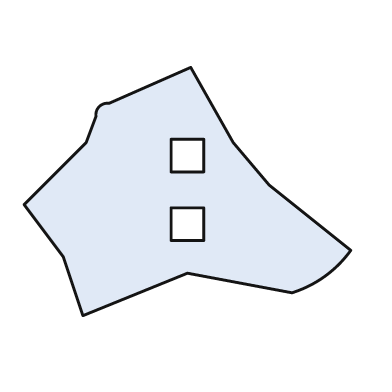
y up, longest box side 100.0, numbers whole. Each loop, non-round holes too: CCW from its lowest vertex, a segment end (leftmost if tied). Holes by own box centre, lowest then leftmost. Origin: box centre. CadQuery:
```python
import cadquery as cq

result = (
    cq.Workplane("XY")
    .moveTo(-32.0, -38.0)
    .lineTo(0.0, -25.0)
    .lineTo(32.0, -31.0)
    .threePointArc((42.0, -26.0), (50.0, -18.0))
    .lineTo(25.0, 2.0)
    .lineTo(14.0, 15.0)
    .lineTo(1.0, 38.0)
    .lineTo(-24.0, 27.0)
    .threePointArc((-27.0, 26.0), (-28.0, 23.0))
    .lineTo(-31.0, 15.0)
    .lineTo(-50.0, -4.0)
    .lineTo(-38.0, -20.0)
    .close()
    .moveTo(-5.0, -15.0)
    .lineTo(5.0, -15.0)
    .lineTo(5.0, -5.0)
    .lineTo(-5.0, -5.0)
    .close()
    .moveTo(-5.0, 6.0)
    .lineTo(5.0, 6.0)
    .lineTo(5.0, 16.0)
    .lineTo(-5.0, 16.0)
    .close()
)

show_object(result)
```